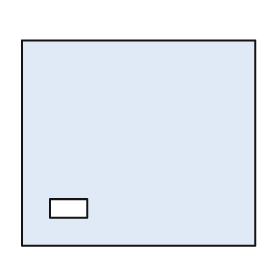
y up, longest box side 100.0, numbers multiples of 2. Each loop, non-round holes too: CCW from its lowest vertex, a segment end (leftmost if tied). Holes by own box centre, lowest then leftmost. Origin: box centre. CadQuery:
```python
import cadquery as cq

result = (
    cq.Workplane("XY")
    .moveTo(-50.0, -44.0)
    .lineTo(50.0, -44.0)
    .lineTo(50.0, 44.0)
    .lineTo(-50.0, 44.0)
    .close()
    .moveTo(-38.0, -32.0)
    .lineTo(-22.0, -32.0)
    .lineTo(-22.0, -24.0)
    .lineTo(-38.0, -24.0)
    .close()
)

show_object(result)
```